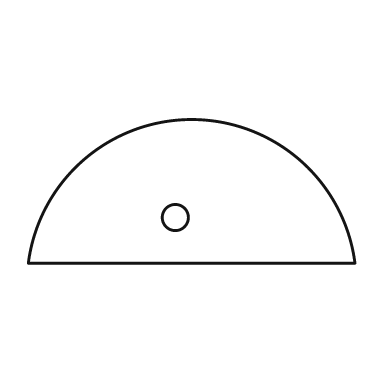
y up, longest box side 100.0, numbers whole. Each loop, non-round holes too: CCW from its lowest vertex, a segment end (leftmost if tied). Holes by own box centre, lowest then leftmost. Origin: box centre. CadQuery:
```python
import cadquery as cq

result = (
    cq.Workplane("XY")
    .moveTo(-50.0, -22.0)
    .lineTo(50.0, -22.0)
    .threePointArc((0.0, 22.0), (-50.0, -22.0))
    .close()
    .moveTo(-5.0, -8.0)
    .circle(4.0)
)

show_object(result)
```